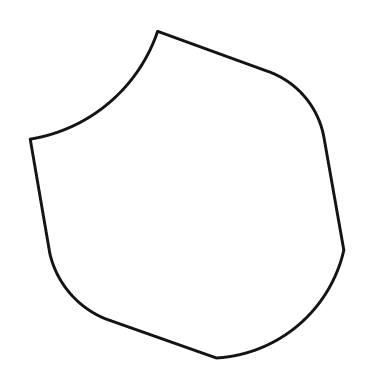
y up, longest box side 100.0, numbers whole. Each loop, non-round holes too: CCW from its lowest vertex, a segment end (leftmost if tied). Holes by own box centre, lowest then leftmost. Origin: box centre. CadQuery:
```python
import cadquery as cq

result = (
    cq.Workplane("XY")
    .moveTo(9.0, -50.0)
    .threePointArc((34.0, -40.0), (48.0, -17.0))
    .lineTo(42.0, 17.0)
    .threePointArc((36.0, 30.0), (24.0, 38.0))
    .lineTo(-9.0, 50.0)
    .threePointArc((-24.0, 28.0), (-48.0, 17.0))
    .lineTo(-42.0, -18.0)
    .threePointArc((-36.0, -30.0), (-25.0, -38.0))
    .close()
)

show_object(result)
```